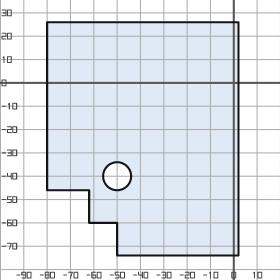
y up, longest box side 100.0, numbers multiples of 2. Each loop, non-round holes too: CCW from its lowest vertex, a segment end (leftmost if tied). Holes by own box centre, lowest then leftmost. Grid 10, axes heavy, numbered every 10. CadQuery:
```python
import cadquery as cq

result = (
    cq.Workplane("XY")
    .moveTo(-50.0, -74.0)
    .lineTo(2.0, -74.0)
    .lineTo(2.0, 26.0)
    .lineTo(-80.0, 26.0)
    .lineTo(-80.0, -46.0)
    .lineTo(-62.0, -46.0)
    .lineTo(-62.0, -60.0)
    .lineTo(-50.0, -60.0)
    .close()
    .moveTo(-50.0, -40.0)
    .circle(6.0)
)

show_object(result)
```